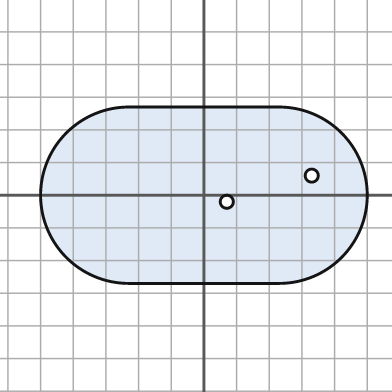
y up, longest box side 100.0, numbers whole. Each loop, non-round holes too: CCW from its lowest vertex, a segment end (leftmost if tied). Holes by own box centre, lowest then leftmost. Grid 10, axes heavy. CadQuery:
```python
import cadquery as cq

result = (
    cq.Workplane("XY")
    .moveTo(-23.0, -27.0)
    .lineTo(23.0, -27.0)
    .threePointArc((50.0, 0.0), (23.0, 27.0))
    .lineTo(-23.0, 27.0)
    .threePointArc((-50.0, 0.0), (-23.0, -27.0))
    .close()
    .moveTo(7.0, -2.0)
    .circle(2.0)
    .moveTo(33.0, 6.0)
    .circle(2.0)
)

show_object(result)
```